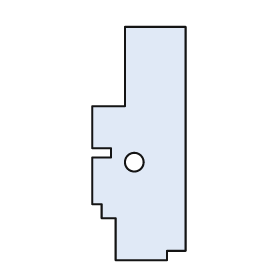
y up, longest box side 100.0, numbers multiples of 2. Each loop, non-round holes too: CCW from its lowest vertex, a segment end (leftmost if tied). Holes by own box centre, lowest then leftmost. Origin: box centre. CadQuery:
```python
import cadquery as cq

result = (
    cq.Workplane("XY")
    .moveTo(-10.0, -50.0)
    .lineTo(12.0, -50.0)
    .lineTo(12.0, -46.0)
    .lineTo(20.0, -46.0)
    .lineTo(20.0, 50.0)
    .lineTo(-6.0, 50.0)
    .lineTo(-6.0, 16.0)
    .lineTo(-20.0, 16.0)
    .lineTo(-20.0, -2.0)
    .lineTo(-12.0, -2.0)
    .lineTo(-12.0, -6.0)
    .lineTo(-20.0, -6.0)
    .lineTo(-20.0, -26.0)
    .lineTo(-16.0, -26.0)
    .lineTo(-16.0, -32.0)
    .lineTo(-10.0, -32.0)
    .close()
    .moveTo(-2.0, -8.0)
    .circle(4.0)
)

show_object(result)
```